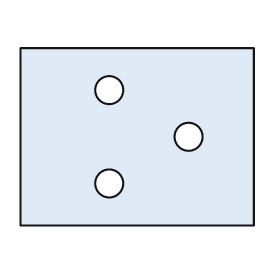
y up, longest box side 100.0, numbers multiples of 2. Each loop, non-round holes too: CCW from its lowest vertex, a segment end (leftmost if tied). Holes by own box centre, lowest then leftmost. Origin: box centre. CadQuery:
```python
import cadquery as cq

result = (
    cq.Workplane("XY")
    .moveTo(-50.0, -38.0)
    .lineTo(50.0, -38.0)
    .lineTo(50.0, 38.0)
    .lineTo(-50.0, 38.0)
    .close()
    .moveTo(-12.0, -20.0)
    .circle(6.0)
    .moveTo(22.0, 0.0)
    .circle(6.0)
    .moveTo(-12.0, 20.0)
    .circle(6.0)
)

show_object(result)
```